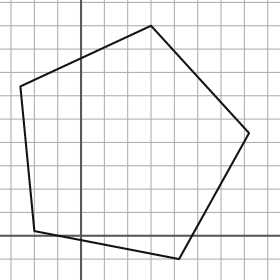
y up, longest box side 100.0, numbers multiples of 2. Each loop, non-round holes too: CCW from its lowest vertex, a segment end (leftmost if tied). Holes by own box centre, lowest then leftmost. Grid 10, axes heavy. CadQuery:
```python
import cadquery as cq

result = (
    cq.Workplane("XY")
    .moveTo(42.0, -10.0)
    .lineTo(72.0, 44.0)
    .lineTo(30.0, 90.0)
    .lineTo(-26.0, 64.0)
    .lineTo(-20.0, 2.0)
    .close()
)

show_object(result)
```